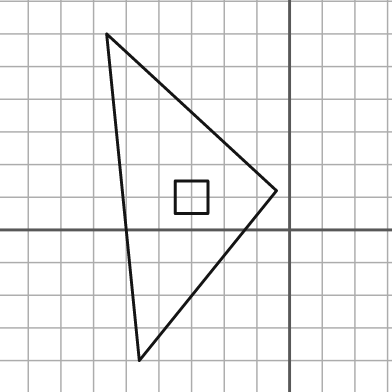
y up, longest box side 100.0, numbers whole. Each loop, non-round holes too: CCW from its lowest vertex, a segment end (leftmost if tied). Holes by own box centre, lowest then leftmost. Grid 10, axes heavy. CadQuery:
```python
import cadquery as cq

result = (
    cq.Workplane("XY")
    .moveTo(-46.0, -40.0)
    .lineTo(-4.0, 12.0)
    .lineTo(-56.0, 60.0)
    .close()
    .moveTo(-35.0, 5.0)
    .lineTo(-25.0, 5.0)
    .lineTo(-25.0, 15.0)
    .lineTo(-35.0, 15.0)
    .close()
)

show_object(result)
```